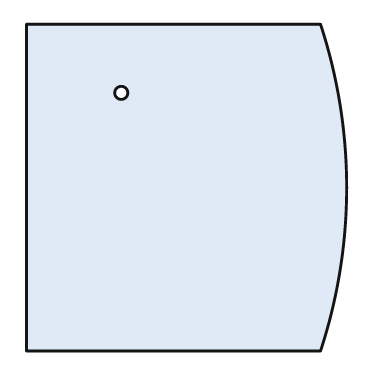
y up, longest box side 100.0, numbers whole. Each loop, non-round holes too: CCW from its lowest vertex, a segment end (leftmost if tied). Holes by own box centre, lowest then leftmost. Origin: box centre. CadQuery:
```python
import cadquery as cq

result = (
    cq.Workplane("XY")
    .moveTo(-49.0, -50.0)
    .lineTo(41.0, -50.0)
    .threePointArc((49.0, 0.0), (41.0, 50.0))
    .lineTo(-49.0, 50.0)
    .close()
    .moveTo(-20.0, 29.0)
    .circle(2.0)
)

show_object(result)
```